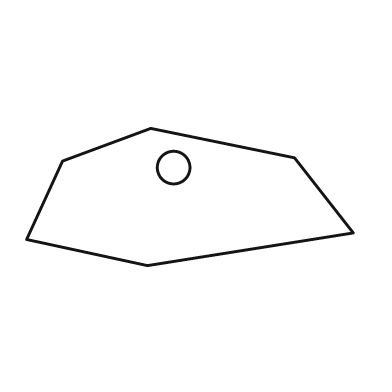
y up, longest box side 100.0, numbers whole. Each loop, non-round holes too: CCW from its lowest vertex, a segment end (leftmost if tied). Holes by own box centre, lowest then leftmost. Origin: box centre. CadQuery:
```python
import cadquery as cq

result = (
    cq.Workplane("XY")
    .moveTo(-13.0, -21.0)
    .lineTo(50.0, -11.0)
    .lineTo(32.0, 12.0)
    .lineTo(-12.0, 21.0)
    .lineTo(-39.0, 11.0)
    .lineTo(-50.0, -13.0)
    .close()
    .moveTo(-5.0, 9.0)
    .circle(5.0)
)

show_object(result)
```